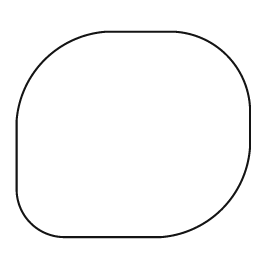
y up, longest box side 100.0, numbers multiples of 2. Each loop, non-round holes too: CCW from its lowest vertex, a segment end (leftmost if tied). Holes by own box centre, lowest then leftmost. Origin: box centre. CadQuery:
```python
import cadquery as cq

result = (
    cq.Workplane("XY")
    .moveTo(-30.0, -44.0)
    .lineTo(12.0, -44.0)
    .threePointArc((38.0, -32.0), (50.0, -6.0))
    .lineTo(50.0, 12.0)
    .threePointArc((40.0, 34.0), (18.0, 44.0))
    .lineTo(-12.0, 44.0)
    .threePointArc((-38.0, 32.0), (-50.0, 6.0))
    .lineTo(-50.0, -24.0)
    .threePointArc((-44.0, -38.0), (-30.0, -44.0))
    .close()
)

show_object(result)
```